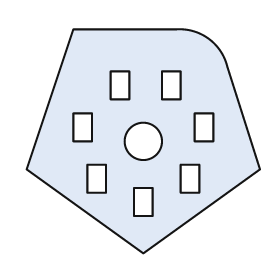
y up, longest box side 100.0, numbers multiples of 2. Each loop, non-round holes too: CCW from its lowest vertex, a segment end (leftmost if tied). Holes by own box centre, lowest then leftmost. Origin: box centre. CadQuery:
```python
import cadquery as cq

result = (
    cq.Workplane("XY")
    .moveTo(0.0, -48.0)
    .lineTo(50.0, -12.0)
    .lineTo(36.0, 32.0)
    .threePointArc((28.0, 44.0), (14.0, 48.0))
    .lineTo(-30.0, 48.0)
    .lineTo(-50.0, -12.0)
    .close()
    .moveTo(-4.0, -32.0)
    .lineTo(4.0, -32.0)
    .lineTo(4.0, -20.0)
    .lineTo(-4.0, -20.0)
    .close()
    .moveTo(-24.0, -22.0)
    .lineTo(-16.0, -22.0)
    .lineTo(-16.0, -10.0)
    .lineTo(-24.0, -10.0)
    .close()
    .moveTo(16.0, -22.0)
    .lineTo(24.0, -22.0)
    .lineTo(24.0, -10.0)
    .lineTo(16.0, -10.0)
    .close()
    .moveTo(0.0, 0.0)
    .circle(8.0)
    .moveTo(-30.0, 0.0)
    .lineTo(-22.0, 0.0)
    .lineTo(-22.0, 12.0)
    .lineTo(-30.0, 12.0)
    .close()
    .moveTo(22.0, 0.0)
    .lineTo(30.0, 0.0)
    .lineTo(30.0, 12.0)
    .lineTo(22.0, 12.0)
    .close()
    .moveTo(-14.0, 18.0)
    .lineTo(-6.0, 18.0)
    .lineTo(-6.0, 30.0)
    .lineTo(-14.0, 30.0)
    .close()
    .moveTo(8.0, 18.0)
    .lineTo(16.0, 18.0)
    .lineTo(16.0, 30.0)
    .lineTo(8.0, 30.0)
    .close()
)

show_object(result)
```